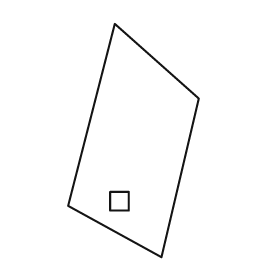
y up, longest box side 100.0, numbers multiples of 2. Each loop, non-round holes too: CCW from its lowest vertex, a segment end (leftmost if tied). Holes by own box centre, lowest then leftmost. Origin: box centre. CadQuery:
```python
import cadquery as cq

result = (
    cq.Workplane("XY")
    .moveTo(12.0, -50.0)
    .lineTo(28.0, 18.0)
    .lineTo(-8.0, 50.0)
    .lineTo(-28.0, -28.0)
    .close()
    .moveTo(-10.0, -30.0)
    .lineTo(-2.0, -30.0)
    .lineTo(-2.0, -22.0)
    .lineTo(-10.0, -22.0)
    .close()
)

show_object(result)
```